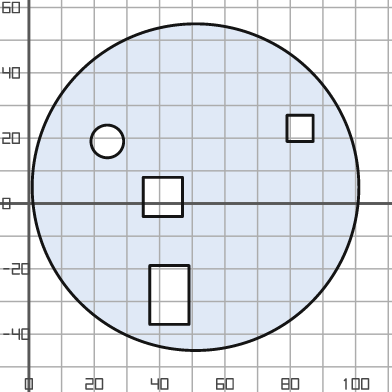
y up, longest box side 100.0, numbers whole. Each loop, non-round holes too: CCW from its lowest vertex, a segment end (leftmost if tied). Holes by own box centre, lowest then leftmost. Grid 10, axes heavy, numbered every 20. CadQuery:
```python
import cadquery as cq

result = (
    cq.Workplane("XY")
    .moveTo(51.0, 5.0)
    .circle(50.0)
    .moveTo(37.0, -37.0)
    .lineTo(49.0, -37.0)
    .lineTo(49.0, -19.0)
    .lineTo(37.0, -19.0)
    .close()
    .moveTo(35.0, -4.0)
    .lineTo(47.0, -4.0)
    .lineTo(47.0, 8.0)
    .lineTo(35.0, 8.0)
    .close()
    .moveTo(24.0, 19.0)
    .circle(5.0)
    .moveTo(79.0, 19.0)
    .lineTo(87.0, 19.0)
    .lineTo(87.0, 27.0)
    .lineTo(79.0, 27.0)
    .close()
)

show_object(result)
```